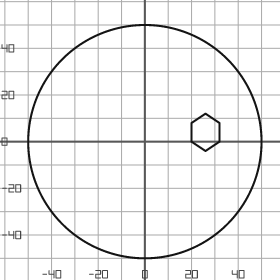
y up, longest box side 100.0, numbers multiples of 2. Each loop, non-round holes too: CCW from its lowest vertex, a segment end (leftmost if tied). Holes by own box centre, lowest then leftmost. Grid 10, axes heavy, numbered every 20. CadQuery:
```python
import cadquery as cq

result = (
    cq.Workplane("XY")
    .moveTo(0.0, 0.0)
    .circle(50.0)
    .moveTo(26.0, -4.0)
    .lineTo(32.0, 0.0)
    .lineTo(32.0, 8.0)
    .lineTo(26.0, 12.0)
    .lineTo(20.0, 8.0)
    .lineTo(20.0, 0.0)
    .close()
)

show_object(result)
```